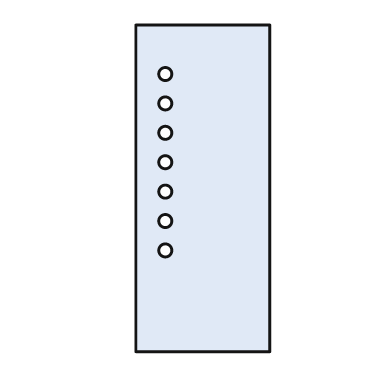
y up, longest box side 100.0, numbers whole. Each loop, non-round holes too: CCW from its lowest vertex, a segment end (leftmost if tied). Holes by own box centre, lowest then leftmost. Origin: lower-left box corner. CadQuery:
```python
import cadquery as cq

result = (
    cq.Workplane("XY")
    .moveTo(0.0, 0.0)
    .lineTo(41.0, 0.0)
    .lineTo(41.0, 100.0)
    .lineTo(0.0, 100.0)
    .close()
    .moveTo(9.0, 31.0)
    .circle(2.0)
    .moveTo(9.0, 40.0)
    .circle(2.0)
    .moveTo(9.0, 49.0)
    .circle(2.0)
    .moveTo(9.0, 58.0)
    .circle(2.0)
    .moveTo(9.0, 67.0)
    .circle(2.0)
    .moveTo(9.0, 76.0)
    .circle(2.0)
    .moveTo(9.0, 85.0)
    .circle(2.0)
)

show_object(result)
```